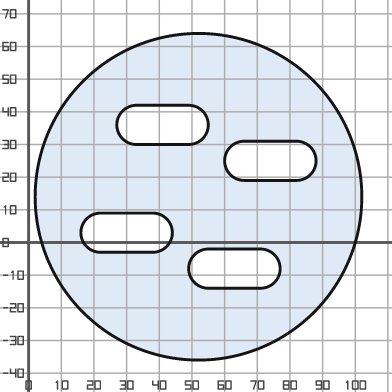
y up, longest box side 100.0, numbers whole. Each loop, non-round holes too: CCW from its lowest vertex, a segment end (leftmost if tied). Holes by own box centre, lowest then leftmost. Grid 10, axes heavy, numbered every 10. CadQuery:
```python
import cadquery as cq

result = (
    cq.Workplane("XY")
    .moveTo(52.0, 14.0)
    .circle(50.0)
    .moveTo(55.0, -14.0)
    .lineTo(71.0, -14.0)
    .threePointArc((77.0, -8.0), (71.0, -2.0))
    .lineTo(55.0, -2.0)
    .threePointArc((49.0, -8.0), (55.0, -14.0))
    .close()
    .moveTo(22.0, -3.0)
    .lineTo(38.0, -3.0)
    .threePointArc((44.0, 3.0), (38.0, 9.0))
    .lineTo(22.0, 9.0)
    .threePointArc((16.0, 3.0), (22.0, -3.0))
    .close()
    .moveTo(66.0, 19.0)
    .lineTo(82.0, 19.0)
    .threePointArc((88.0, 25.0), (82.0, 31.0))
    .lineTo(66.0, 31.0)
    .threePointArc((60.0, 25.0), (66.0, 19.0))
    .close()
    .moveTo(33.0, 30.0)
    .lineTo(49.0, 30.0)
    .threePointArc((55.0, 36.0), (49.0, 42.0))
    .lineTo(33.0, 42.0)
    .threePointArc((27.0, 36.0), (33.0, 30.0))
    .close()
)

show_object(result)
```